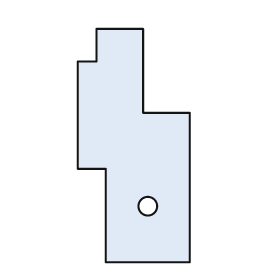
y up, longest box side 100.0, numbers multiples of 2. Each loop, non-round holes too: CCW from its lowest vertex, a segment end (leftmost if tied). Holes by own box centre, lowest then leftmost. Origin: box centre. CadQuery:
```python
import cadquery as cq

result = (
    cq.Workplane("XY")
    .moveTo(-12.0, -50.0)
    .lineTo(24.0, -50.0)
    .lineTo(24.0, 14.0)
    .lineTo(4.0, 14.0)
    .lineTo(4.0, 50.0)
    .lineTo(-16.0, 50.0)
    .lineTo(-16.0, 36.0)
    .lineTo(-24.0, 36.0)
    .lineTo(-24.0, -10.0)
    .lineTo(-12.0, -10.0)
    .close()
    .moveTo(6.0, -26.0)
    .circle(4.0)
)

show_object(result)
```